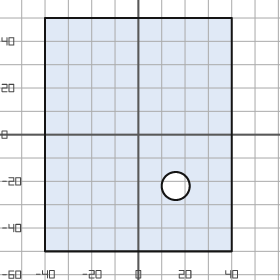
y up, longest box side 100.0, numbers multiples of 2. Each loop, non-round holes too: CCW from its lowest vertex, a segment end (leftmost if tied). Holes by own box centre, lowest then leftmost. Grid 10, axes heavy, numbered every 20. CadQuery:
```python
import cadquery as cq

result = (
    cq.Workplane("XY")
    .moveTo(-40.0, -50.0)
    .lineTo(40.0, -50.0)
    .lineTo(40.0, 50.0)
    .lineTo(-40.0, 50.0)
    .close()
    .moveTo(16.0, -22.0)
    .circle(6.0)
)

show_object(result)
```